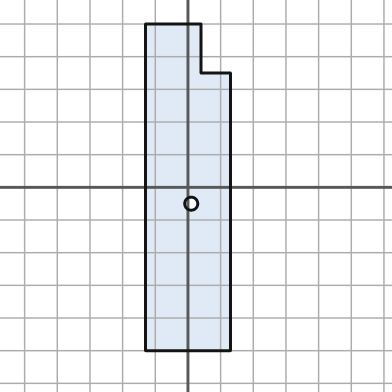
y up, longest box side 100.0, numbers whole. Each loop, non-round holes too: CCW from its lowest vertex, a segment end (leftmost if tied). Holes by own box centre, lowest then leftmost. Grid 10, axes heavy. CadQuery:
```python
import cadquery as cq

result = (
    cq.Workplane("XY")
    .moveTo(-13.0, -50.0)
    .lineTo(13.0, -50.0)
    .lineTo(13.0, 35.0)
    .lineTo(4.0, 35.0)
    .lineTo(4.0, 50.0)
    .lineTo(-13.0, 50.0)
    .close()
    .moveTo(1.0, -5.0)
    .circle(2.0)
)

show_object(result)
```